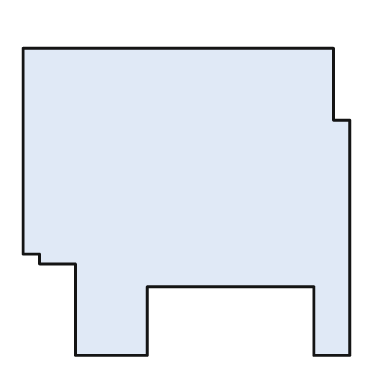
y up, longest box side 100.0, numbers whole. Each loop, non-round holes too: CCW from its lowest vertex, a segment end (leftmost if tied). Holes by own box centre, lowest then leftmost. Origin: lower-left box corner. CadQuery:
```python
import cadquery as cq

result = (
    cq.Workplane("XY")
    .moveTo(16.0, 0.0)
    .lineTo(38.0, 0.0)
    .lineTo(38.0, 21.0)
    .lineTo(89.0, 21.0)
    .lineTo(89.0, 0.0)
    .lineTo(100.0, 0.0)
    .lineTo(100.0, 72.0)
    .lineTo(95.0, 72.0)
    .lineTo(95.0, 94.0)
    .lineTo(0.0, 94.0)
    .lineTo(0.0, 31.0)
    .lineTo(5.0, 31.0)
    .lineTo(5.0, 28.0)
    .lineTo(16.0, 28.0)
    .close()
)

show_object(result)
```